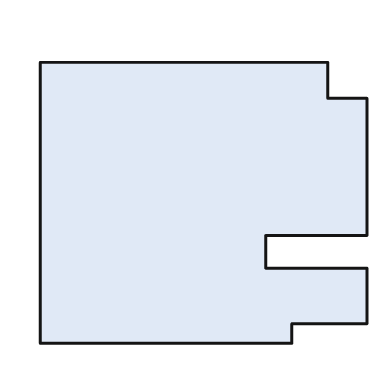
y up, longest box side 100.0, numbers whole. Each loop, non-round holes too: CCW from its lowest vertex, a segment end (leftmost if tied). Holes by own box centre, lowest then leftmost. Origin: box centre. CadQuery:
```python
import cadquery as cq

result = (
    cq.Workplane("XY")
    .moveTo(-50.0, -43.0)
    .lineTo(27.0, -43.0)
    .lineTo(27.0, -37.0)
    .lineTo(50.0, -37.0)
    .lineTo(50.0, -20.0)
    .lineTo(19.0, -20.0)
    .lineTo(19.0, -10.0)
    .lineTo(50.0, -10.0)
    .lineTo(50.0, 32.0)
    .lineTo(38.0, 32.0)
    .lineTo(38.0, 43.0)
    .lineTo(-50.0, 43.0)
    .close()
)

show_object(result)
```